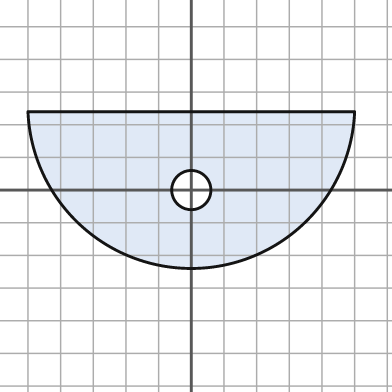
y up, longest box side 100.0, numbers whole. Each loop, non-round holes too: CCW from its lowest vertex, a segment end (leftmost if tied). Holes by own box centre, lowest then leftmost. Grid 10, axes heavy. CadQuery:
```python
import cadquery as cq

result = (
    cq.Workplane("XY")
    .moveTo(-50.0, 24.0)
    .threePointArc((0.0, -24.0), (50.0, 24.0))
    .close()
    .moveTo(0.0, 0.0)
    .circle(6.0)
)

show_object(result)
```